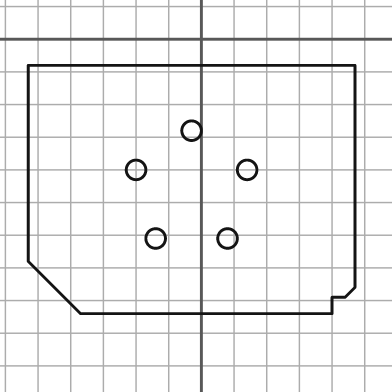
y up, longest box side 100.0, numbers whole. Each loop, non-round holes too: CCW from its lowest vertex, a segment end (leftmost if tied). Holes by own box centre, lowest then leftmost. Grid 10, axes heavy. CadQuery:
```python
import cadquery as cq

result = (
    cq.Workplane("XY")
    .moveTo(-37.0, -84.0)
    .lineTo(40.0, -84.0)
    .lineTo(40.0, -79.0)
    .lineTo(44.0, -79.0)
    .lineTo(47.0, -76.0)
    .lineTo(47.0, -8.0)
    .lineTo(-53.0, -8.0)
    .lineTo(-53.0, -68.0)
    .close()
    .moveTo(-14.0, -61.0)
    .circle(3.0)
    .moveTo(8.0, -61.0)
    .circle(3.0)
    .moveTo(-20.0, -40.0)
    .circle(3.0)
    .moveTo(14.0, -40.0)
    .circle(3.0)
    .moveTo(-3.0, -28.0)
    .circle(3.0)
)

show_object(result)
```